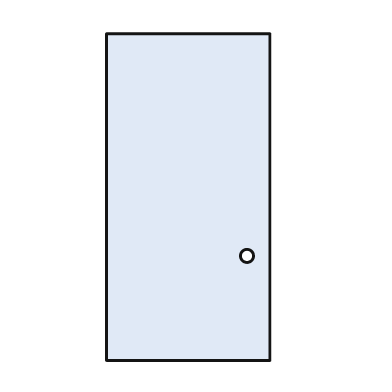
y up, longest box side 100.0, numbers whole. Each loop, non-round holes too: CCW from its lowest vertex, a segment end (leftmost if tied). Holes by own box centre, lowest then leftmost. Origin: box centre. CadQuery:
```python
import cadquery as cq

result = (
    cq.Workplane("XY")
    .moveTo(-25.0, -50.0)
    .lineTo(25.0, -50.0)
    .lineTo(25.0, 50.0)
    .lineTo(-25.0, 50.0)
    .close()
    .moveTo(18.0, -18.0)
    .circle(2.0)
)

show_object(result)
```